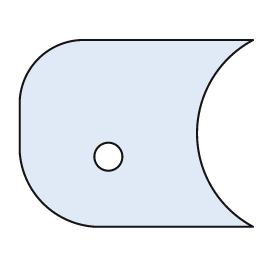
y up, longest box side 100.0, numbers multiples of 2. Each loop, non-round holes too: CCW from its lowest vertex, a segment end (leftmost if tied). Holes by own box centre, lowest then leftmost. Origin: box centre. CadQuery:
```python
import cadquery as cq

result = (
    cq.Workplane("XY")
    .moveTo(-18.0, -40.0)
    .lineTo(50.0, -40.0)
    .threePointArc((26.0, 0.0), (50.0, 40.0))
    .lineTo(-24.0, 40.0)
    .threePointArc((-42.0, 32.0), (-50.0, 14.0))
    .lineTo(-50.0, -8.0)
    .threePointArc((-40.0, -30.0), (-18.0, -40.0))
    .close()
    .moveTo(-12.0, -10.0)
    .circle(6.0)
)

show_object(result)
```